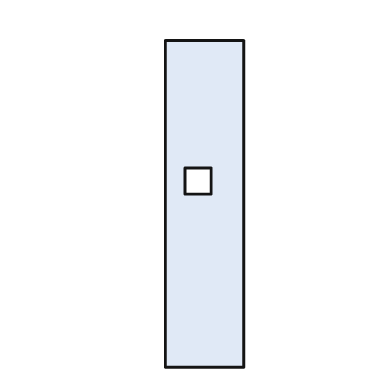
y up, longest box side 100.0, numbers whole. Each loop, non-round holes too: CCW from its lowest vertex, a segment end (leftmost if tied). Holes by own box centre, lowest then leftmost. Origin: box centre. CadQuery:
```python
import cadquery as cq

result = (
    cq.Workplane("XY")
    .moveTo(-12.0, -50.0)
    .lineTo(12.0, -50.0)
    .lineTo(12.0, 50.0)
    .lineTo(-12.0, 50.0)
    .close()
    .moveTo(-6.0, 3.0)
    .lineTo(2.0, 3.0)
    .lineTo(2.0, 11.0)
    .lineTo(-6.0, 11.0)
    .close()
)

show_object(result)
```